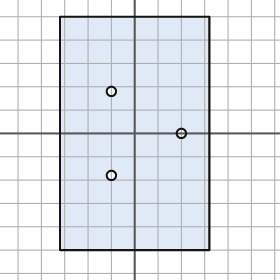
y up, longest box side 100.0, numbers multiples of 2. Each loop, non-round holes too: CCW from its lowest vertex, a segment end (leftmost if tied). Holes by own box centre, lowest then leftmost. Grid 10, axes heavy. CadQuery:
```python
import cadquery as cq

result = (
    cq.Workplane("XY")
    .moveTo(-32.0, -50.0)
    .lineTo(32.0, -50.0)
    .lineTo(32.0, 50.0)
    .lineTo(-32.0, 50.0)
    .close()
    .moveTo(-10.0, -18.0)
    .circle(2.0)
    .moveTo(20.0, 0.0)
    .circle(2.0)
    .moveTo(-10.0, 18.0)
    .circle(2.0)
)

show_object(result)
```